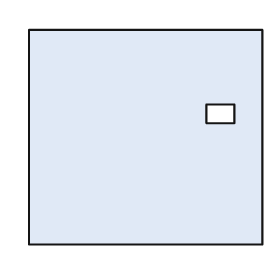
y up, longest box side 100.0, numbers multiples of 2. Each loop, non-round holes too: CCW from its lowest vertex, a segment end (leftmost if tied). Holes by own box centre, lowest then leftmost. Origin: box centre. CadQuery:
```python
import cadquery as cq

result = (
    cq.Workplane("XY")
    .moveTo(-50.0, -46.0)
    .lineTo(50.0, -46.0)
    .lineTo(50.0, 46.0)
    .lineTo(-50.0, 46.0)
    .close()
    .moveTo(26.0, 6.0)
    .lineTo(38.0, 6.0)
    .lineTo(38.0, 14.0)
    .lineTo(26.0, 14.0)
    .close()
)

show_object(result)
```